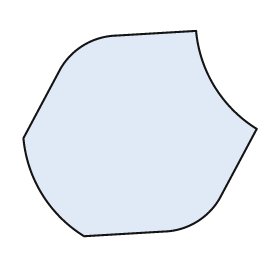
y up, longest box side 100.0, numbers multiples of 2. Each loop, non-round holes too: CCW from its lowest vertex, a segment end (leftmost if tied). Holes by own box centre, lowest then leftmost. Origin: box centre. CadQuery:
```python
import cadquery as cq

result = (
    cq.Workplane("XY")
    .moveTo(-24.0, -44.0)
    .lineTo(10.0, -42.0)
    .threePointArc((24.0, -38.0), (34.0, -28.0))
    .lineTo(50.0, 2.0)
    .threePointArc((32.0, 20.0), (24.0, 44.0))
    .lineTo(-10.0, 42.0)
    .threePointArc((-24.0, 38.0), (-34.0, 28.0))
    .lineTo(-50.0, -2.0)
    .threePointArc((-42.0, -26.0), (-24.0, -44.0))
    .close()
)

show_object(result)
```